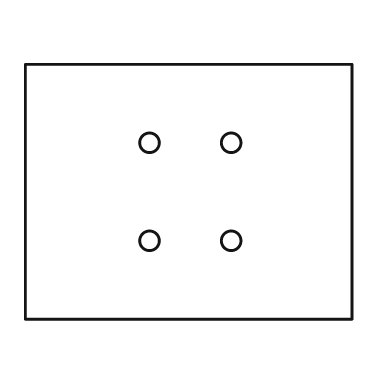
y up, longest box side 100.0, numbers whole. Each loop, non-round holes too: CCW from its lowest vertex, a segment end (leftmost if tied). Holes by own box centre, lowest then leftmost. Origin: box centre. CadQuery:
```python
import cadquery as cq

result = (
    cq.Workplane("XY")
    .moveTo(-50.0, -39.0)
    .lineTo(50.0, -39.0)
    .lineTo(50.0, 39.0)
    .lineTo(-50.0, 39.0)
    .close()
    .moveTo(-12.0, -15.0)
    .circle(3.0)
    .moveTo(13.0, -15.0)
    .circle(3.0)
    .moveTo(-12.0, 15.0)
    .circle(3.0)
    .moveTo(13.0, 15.0)
    .circle(3.0)
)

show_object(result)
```